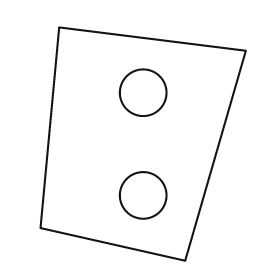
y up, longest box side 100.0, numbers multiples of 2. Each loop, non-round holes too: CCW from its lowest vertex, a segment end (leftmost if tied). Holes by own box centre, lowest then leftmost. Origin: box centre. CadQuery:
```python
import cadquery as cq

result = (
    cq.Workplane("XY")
    .moveTo(18.0, -50.0)
    .lineTo(44.0, 40.0)
    .lineTo(-36.0, 50.0)
    .lineTo(-44.0, -36.0)
    .close()
    .moveTo(0.0, -22.0)
    .circle(10.0)
    .moveTo(0.0, 22.0)
    .circle(10.0)
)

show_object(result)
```